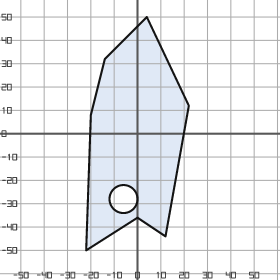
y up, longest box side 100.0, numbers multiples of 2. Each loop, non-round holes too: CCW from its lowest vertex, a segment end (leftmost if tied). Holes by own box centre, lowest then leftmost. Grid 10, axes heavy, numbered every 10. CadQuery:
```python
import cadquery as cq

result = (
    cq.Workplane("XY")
    .moveTo(-22.0, -50.0)
    .lineTo(0.0, -36.0)
    .lineTo(12.0, -44.0)
    .lineTo(22.0, 12.0)
    .lineTo(4.0, 50.0)
    .lineTo(-14.0, 32.0)
    .lineTo(-20.0, 8.0)
    .close()
    .moveTo(-6.0, -28.0)
    .circle(6.0)
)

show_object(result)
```